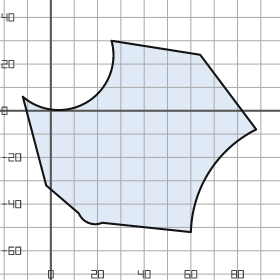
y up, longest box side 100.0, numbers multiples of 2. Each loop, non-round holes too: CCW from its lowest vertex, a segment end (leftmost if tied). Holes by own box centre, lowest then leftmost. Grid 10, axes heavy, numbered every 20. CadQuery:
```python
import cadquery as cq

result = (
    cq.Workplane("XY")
    .moveTo(60.0, -52.0)
    .threePointArc((68.0, -26.0), (88.0, -8.0))
    .lineTo(64.0, 24.0)
    .lineTo(26.0, 30.0)
    .threePointArc((16.0, 4.0), (-12.0, 6.0))
    .lineTo(-2.0, -32.0)
    .lineTo(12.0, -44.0)
    .threePointArc((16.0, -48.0), (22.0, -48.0))
    .close()
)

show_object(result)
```